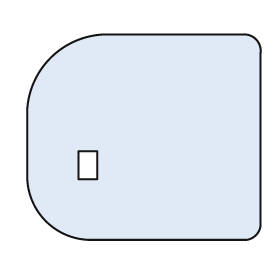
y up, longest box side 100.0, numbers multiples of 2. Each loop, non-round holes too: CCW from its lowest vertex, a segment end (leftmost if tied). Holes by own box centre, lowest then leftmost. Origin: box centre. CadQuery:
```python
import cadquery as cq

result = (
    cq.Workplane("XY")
    .moveTo(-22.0, -44.0)
    .lineTo(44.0, -44.0)
    .threePointArc((48.0, -42.0), (50.0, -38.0))
    .lineTo(50.0, 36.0)
    .threePointArc((48.0, 42.0), (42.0, 44.0))
    .lineTo(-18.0, 44.0)
    .threePointArc((-40.0, 34.0), (-50.0, 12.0))
    .lineTo(-50.0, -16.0)
    .threePointArc((-42.0, -36.0), (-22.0, -44.0))
    .close()
    .moveTo(-28.0, -18.0)
    .lineTo(-20.0, -18.0)
    .lineTo(-20.0, -6.0)
    .lineTo(-28.0, -6.0)
    .close()
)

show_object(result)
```